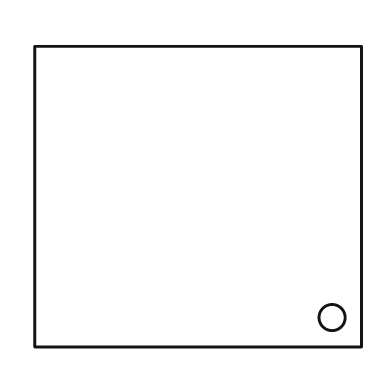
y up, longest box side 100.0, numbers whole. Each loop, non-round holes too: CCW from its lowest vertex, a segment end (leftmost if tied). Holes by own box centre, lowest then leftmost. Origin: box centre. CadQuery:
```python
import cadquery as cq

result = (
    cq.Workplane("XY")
    .moveTo(-50.0, -46.0)
    .lineTo(50.0, -46.0)
    .lineTo(50.0, 46.0)
    .lineTo(-50.0, 46.0)
    .close()
    .moveTo(41.0, -37.0)
    .circle(4.0)
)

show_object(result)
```